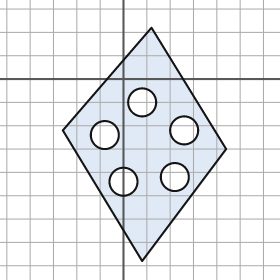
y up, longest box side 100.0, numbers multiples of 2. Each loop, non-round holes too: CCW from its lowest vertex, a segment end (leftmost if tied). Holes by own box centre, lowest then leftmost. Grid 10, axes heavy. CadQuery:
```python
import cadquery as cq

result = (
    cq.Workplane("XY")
    .moveTo(8.0, -78.0)
    .lineTo(44.0, -30.0)
    .lineTo(12.0, 22.0)
    .lineTo(-26.0, -22.0)
    .close()
    .moveTo(0.0, -44.0)
    .circle(6.0)
    .moveTo(22.0, -42.0)
    .circle(6.0)
    .moveTo(-8.0, -24.0)
    .circle(6.0)
    .moveTo(26.0, -22.0)
    .circle(6.0)
    .moveTo(8.0, -10.0)
    .circle(6.0)
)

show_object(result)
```